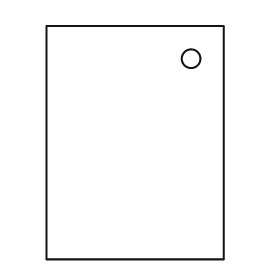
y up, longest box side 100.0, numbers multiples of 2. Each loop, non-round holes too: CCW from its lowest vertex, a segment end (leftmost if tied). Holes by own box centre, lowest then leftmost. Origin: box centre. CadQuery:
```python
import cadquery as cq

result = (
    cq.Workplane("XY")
    .moveTo(-38.0, -50.0)
    .lineTo(38.0, -50.0)
    .lineTo(38.0, 50.0)
    .lineTo(-38.0, 50.0)
    .close()
    .moveTo(24.0, 36.0)
    .circle(4.0)
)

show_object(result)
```